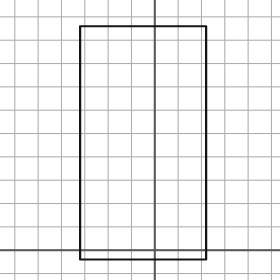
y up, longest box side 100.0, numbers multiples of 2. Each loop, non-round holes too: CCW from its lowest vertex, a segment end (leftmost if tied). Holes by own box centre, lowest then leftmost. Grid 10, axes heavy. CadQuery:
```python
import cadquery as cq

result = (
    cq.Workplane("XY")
    .moveTo(-32.0, -4.0)
    .lineTo(22.0, -4.0)
    .lineTo(22.0, 96.0)
    .lineTo(-32.0, 96.0)
    .close()
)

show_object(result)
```